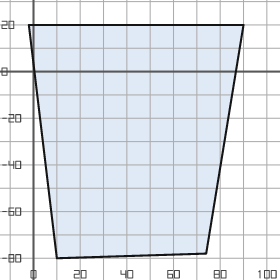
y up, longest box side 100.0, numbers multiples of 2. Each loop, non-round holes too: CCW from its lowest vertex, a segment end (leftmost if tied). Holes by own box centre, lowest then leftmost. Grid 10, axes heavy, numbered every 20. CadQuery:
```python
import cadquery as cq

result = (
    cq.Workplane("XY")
    .moveTo(10.0, -80.0)
    .lineTo(74.0, -78.0)
    .lineTo(90.0, 20.0)
    .lineTo(-2.0, 20.0)
    .close()
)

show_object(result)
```